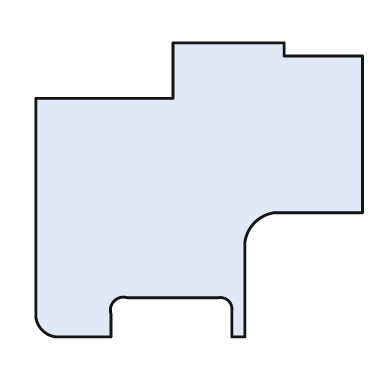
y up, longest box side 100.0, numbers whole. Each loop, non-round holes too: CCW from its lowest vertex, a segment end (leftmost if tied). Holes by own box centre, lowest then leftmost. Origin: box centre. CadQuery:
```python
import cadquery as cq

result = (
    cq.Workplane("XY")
    .moveTo(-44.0, -45.0)
    .lineTo(-27.0, -45.0)
    .lineTo(-27.0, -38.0)
    .threePointArc((-26.0, -34.0), (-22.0, -33.0))
    .lineTo(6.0, -33.0)
    .threePointArc((9.0, -34.0), (10.0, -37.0))
    .lineTo(10.0, -45.0)
    .lineTo(14.0, -45.0)
    .lineTo(14.0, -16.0)
    .threePointArc((17.0, -10.0), (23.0, -7.0))
    .lineTo(50.0, -7.0)
    .lineTo(50.0, 41.0)
    .lineTo(26.0, 41.0)
    .lineTo(26.0, 45.0)
    .lineTo(-8.0, 45.0)
    .lineTo(-8.0, 28.0)
    .lineTo(-50.0, 28.0)
    .lineTo(-50.0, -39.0)
    .threePointArc((-48.0, -43.0), (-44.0, -45.0))
    .close()
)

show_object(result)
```